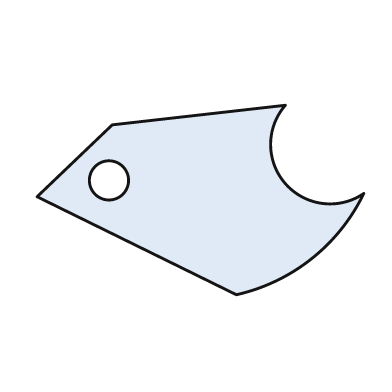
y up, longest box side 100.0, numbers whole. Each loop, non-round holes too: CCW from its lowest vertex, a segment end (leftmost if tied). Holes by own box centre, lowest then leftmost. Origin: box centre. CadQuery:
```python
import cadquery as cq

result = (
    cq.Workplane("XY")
    .moveTo(11.0, -29.0)
    .threePointArc((34.0, -18.0), (50.0, 2.0))
    .threePointArc((26.0, 5.0), (26.0, 29.0))
    .lineTo(-27.0, 23.0)
    .lineTo(-50.0, 1.0)
    .close()
    .moveTo(-28.0, 6.0)
    .circle(6.0)
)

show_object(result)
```